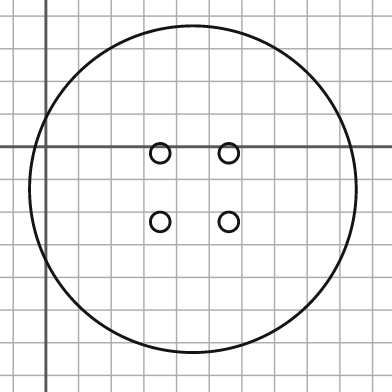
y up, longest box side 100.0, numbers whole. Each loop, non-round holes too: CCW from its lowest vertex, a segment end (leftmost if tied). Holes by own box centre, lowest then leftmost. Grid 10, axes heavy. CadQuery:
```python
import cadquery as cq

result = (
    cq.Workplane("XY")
    .moveTo(45.0, -13.0)
    .circle(50.0)
    .moveTo(35.0, -23.0)
    .circle(3.0)
    .moveTo(56.0, -23.0)
    .circle(3.0)
    .moveTo(35.0, -2.0)
    .circle(3.0)
    .moveTo(56.0, -2.0)
    .circle(3.0)
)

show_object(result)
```